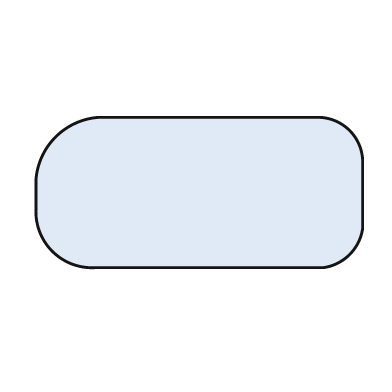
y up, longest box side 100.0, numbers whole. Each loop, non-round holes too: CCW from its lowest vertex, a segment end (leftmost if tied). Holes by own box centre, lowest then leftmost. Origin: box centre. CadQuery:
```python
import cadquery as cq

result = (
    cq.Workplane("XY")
    .moveTo(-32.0, -23.0)
    .lineTo(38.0, -23.0)
    .threePointArc((46.0, -19.0), (50.0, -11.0))
    .lineTo(50.0, 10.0)
    .threePointArc((46.0, 19.0), (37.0, 23.0))
    .lineTo(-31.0, 23.0)
    .threePointArc((-44.0, 17.0), (-50.0, 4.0))
    .lineTo(-50.0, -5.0)
    .threePointArc((-45.0, -18.0), (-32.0, -23.0))
    .close()
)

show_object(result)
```